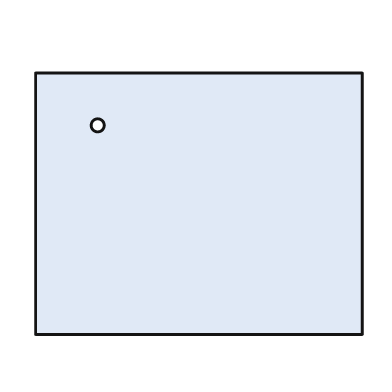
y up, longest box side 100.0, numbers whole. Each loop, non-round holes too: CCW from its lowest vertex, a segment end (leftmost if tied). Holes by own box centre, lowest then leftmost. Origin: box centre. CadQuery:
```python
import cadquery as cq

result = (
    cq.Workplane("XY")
    .moveTo(-50.0, -40.0)
    .lineTo(50.0, -40.0)
    .lineTo(50.0, 40.0)
    .lineTo(-50.0, 40.0)
    .close()
    .moveTo(-31.0, 24.0)
    .circle(2.0)
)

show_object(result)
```